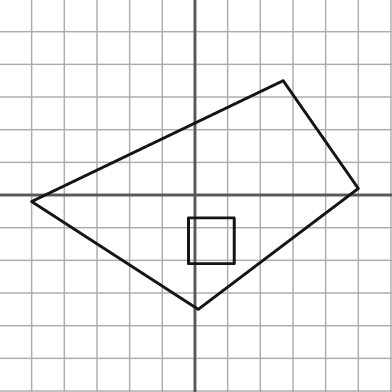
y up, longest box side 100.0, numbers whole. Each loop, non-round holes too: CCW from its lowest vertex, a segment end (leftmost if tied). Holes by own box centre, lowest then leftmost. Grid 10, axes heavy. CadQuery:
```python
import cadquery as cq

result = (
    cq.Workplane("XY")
    .moveTo(1.0, -35.0)
    .lineTo(50.0, 2.0)
    .lineTo(27.0, 35.0)
    .lineTo(-50.0, -2.0)
    .close()
    .moveTo(-2.0, -21.0)
    .lineTo(12.0, -21.0)
    .lineTo(12.0, -7.0)
    .lineTo(-2.0, -7.0)
    .close()
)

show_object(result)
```